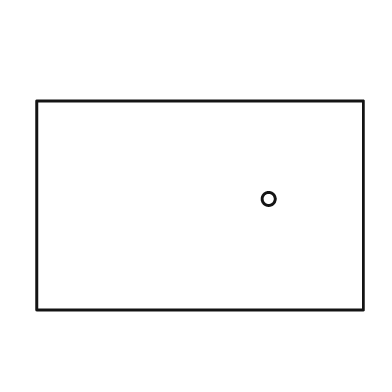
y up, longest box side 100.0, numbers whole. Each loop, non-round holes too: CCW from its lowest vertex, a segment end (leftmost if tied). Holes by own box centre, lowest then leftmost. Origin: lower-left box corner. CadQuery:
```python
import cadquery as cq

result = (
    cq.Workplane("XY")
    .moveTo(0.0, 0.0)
    .lineTo(100.0, 0.0)
    .lineTo(100.0, 64.0)
    .lineTo(0.0, 64.0)
    .close()
    .moveTo(71.0, 34.0)
    .circle(2.0)
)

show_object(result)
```